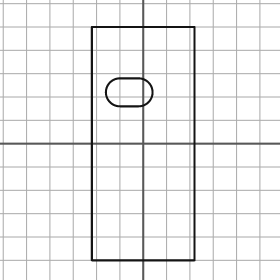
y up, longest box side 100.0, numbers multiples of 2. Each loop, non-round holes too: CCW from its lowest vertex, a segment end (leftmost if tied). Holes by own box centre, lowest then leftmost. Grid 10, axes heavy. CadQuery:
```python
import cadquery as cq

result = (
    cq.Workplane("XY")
    .moveTo(-22.0, -50.0)
    .lineTo(22.0, -50.0)
    .lineTo(22.0, 50.0)
    .lineTo(-22.0, 50.0)
    .close()
    .moveTo(-10.0, 16.0)
    .lineTo(-2.0, 16.0)
    .threePointArc((4.0, 22.0), (-2.0, 28.0))
    .lineTo(-10.0, 28.0)
    .threePointArc((-16.0, 22.0), (-10.0, 16.0))
    .close()
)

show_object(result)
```